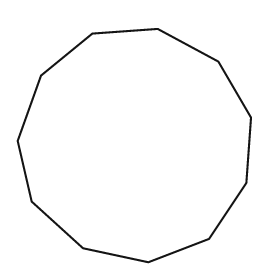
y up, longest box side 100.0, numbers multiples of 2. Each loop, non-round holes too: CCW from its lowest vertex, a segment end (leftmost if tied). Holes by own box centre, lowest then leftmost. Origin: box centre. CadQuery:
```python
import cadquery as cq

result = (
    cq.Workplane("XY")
    .moveTo(6.0, -50.0)
    .lineTo(32.0, -40.0)
    .lineTo(48.0, -16.0)
    .lineTo(50.0, 12.0)
    .lineTo(36.0, 36.0)
    .lineTo(10.0, 50.0)
    .lineTo(-18.0, 48.0)
    .lineTo(-40.0, 30.0)
    .lineTo(-50.0, 2.0)
    .lineTo(-44.0, -24.0)
    .lineTo(-22.0, -44.0)
    .close()
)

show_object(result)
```